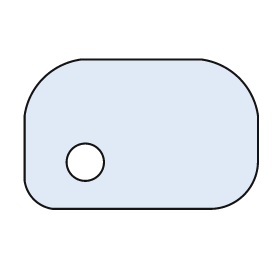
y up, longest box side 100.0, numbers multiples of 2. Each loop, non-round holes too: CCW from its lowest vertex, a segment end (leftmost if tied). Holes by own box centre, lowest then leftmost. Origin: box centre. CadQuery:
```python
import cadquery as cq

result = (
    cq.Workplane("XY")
    .moveTo(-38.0, -32.0)
    .lineTo(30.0, -32.0)
    .threePointArc((44.0, -26.0), (50.0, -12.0))
    .lineTo(50.0, 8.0)
    .threePointArc((42.0, 24.0), (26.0, 32.0))
    .lineTo(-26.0, 32.0)
    .threePointArc((-42.0, 24.0), (-50.0, 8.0))
    .lineTo(-50.0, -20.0)
    .threePointArc((-46.0, -28.0), (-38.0, -32.0))
    .close()
    .moveTo(-24.0, -12.0)
    .circle(8.0)
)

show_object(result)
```